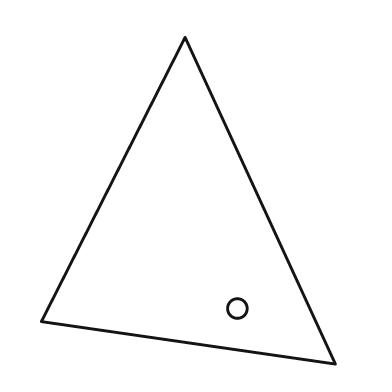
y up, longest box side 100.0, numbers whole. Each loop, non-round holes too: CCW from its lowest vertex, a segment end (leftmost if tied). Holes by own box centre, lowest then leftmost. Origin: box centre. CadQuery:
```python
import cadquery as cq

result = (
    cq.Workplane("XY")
    .moveTo(45.0, -50.0)
    .lineTo(-1.0, 50.0)
    .lineTo(-45.0, -37.0)
    .close()
    .moveTo(15.0, -33.0)
    .circle(3.0)
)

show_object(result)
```